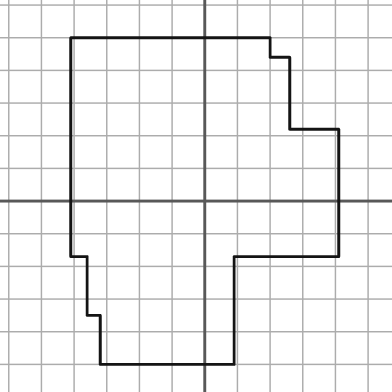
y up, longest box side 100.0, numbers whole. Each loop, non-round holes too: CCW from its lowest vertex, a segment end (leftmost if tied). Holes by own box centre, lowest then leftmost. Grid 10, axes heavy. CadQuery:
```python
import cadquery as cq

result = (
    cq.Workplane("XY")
    .moveTo(-32.0, -50.0)
    .lineTo(9.0, -50.0)
    .lineTo(9.0, -17.0)
    .lineTo(41.0, -17.0)
    .lineTo(41.0, 22.0)
    .lineTo(26.0, 22.0)
    .lineTo(26.0, 44.0)
    .lineTo(20.0, 44.0)
    .lineTo(20.0, 50.0)
    .lineTo(-41.0, 50.0)
    .lineTo(-41.0, -17.0)
    .lineTo(-36.0, -17.0)
    .lineTo(-36.0, -35.0)
    .lineTo(-32.0, -35.0)
    .close()
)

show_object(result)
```